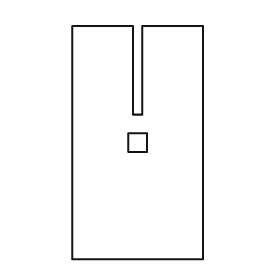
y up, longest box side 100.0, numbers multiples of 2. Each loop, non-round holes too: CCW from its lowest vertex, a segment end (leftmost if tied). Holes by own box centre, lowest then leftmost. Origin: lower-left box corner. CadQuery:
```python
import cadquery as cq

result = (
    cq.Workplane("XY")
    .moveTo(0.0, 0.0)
    .lineTo(56.0, 0.0)
    .lineTo(56.0, 100.0)
    .lineTo(30.0, 100.0)
    .lineTo(30.0, 62.0)
    .lineTo(26.0, 62.0)
    .lineTo(26.0, 100.0)
    .lineTo(0.0, 100.0)
    .close()
    .moveTo(24.0, 46.0)
    .lineTo(32.0, 46.0)
    .lineTo(32.0, 54.0)
    .lineTo(24.0, 54.0)
    .close()
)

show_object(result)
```